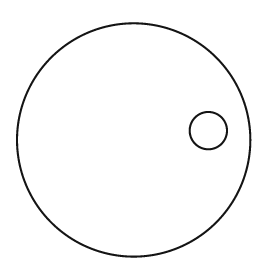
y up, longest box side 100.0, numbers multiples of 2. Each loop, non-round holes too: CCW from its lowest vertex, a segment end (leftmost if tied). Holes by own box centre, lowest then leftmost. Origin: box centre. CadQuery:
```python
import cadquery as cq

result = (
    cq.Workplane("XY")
    .moveTo(0.0, 0.0)
    .circle(50.0)
    .moveTo(32.0, 4.0)
    .circle(8.0)
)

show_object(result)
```